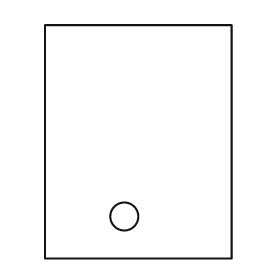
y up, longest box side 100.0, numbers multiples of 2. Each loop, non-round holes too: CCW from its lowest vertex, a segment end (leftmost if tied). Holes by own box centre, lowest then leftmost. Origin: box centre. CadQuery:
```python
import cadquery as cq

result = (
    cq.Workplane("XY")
    .moveTo(-40.0, -50.0)
    .lineTo(40.0, -50.0)
    .lineTo(40.0, 50.0)
    .lineTo(-40.0, 50.0)
    .close()
    .moveTo(-6.0, -32.0)
    .circle(6.0)
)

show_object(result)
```